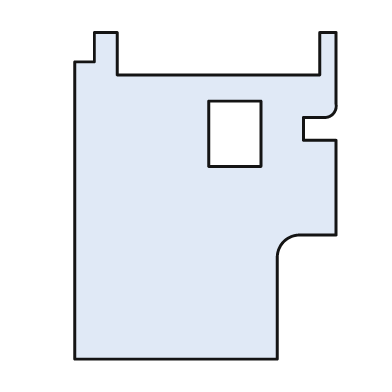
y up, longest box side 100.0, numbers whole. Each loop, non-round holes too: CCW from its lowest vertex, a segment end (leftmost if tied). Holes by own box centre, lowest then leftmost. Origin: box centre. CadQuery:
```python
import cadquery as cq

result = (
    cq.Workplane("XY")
    .moveTo(-40.0, -50.0)
    .lineTo(22.0, -50.0)
    .lineTo(22.0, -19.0)
    .threePointArc((24.0, -14.0), (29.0, -12.0))
    .lineTo(40.0, -12.0)
    .lineTo(40.0, 17.0)
    .lineTo(30.0, 17.0)
    .lineTo(30.0, 24.0)
    .lineTo(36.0, 24.0)
    .threePointArc((39.0, 25.0), (40.0, 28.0))
    .lineTo(40.0, 50.0)
    .lineTo(35.0, 50.0)
    .lineTo(35.0, 37.0)
    .lineTo(-27.0, 37.0)
    .lineTo(-27.0, 50.0)
    .lineTo(-34.0, 50.0)
    .lineTo(-34.0, 41.0)
    .lineTo(-40.0, 41.0)
    .close()
    .moveTo(1.0, 9.0)
    .lineTo(17.0, 9.0)
    .lineTo(17.0, 29.0)
    .lineTo(1.0, 29.0)
    .close()
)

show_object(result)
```